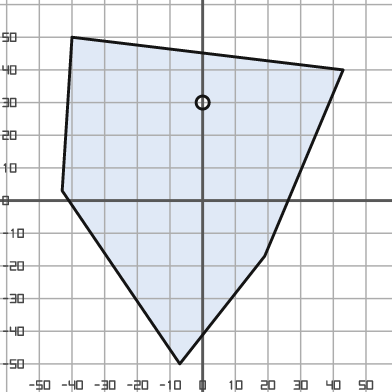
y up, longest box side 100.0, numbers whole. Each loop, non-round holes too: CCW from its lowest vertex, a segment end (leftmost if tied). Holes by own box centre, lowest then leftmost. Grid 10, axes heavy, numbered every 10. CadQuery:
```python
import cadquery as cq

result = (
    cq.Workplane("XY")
    .moveTo(-7.0, -50.0)
    .lineTo(19.0, -17.0)
    .lineTo(43.0, 40.0)
    .lineTo(-40.0, 50.0)
    .lineTo(-43.0, 3.0)
    .close()
    .moveTo(0.0, 30.0)
    .circle(2.0)
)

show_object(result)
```